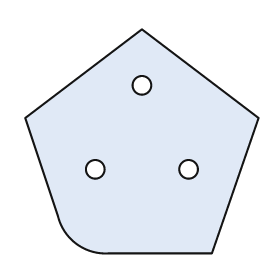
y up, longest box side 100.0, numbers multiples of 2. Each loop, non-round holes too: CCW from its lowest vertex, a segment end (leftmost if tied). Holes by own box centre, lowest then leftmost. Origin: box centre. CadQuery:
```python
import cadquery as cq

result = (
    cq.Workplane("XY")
    .moveTo(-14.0, -48.0)
    .lineTo(30.0, -48.0)
    .lineTo(50.0, 10.0)
    .lineTo(0.0, 48.0)
    .lineTo(-50.0, 10.0)
    .lineTo(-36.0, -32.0)
    .threePointArc((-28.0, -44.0), (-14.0, -48.0))
    .close()
    .moveTo(-20.0, -12.0)
    .circle(4.0)
    .moveTo(20.0, -12.0)
    .circle(4.0)
    .moveTo(0.0, 24.0)
    .circle(4.0)
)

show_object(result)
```